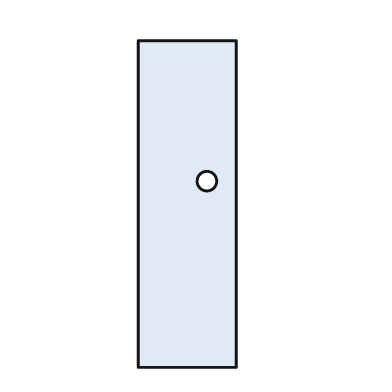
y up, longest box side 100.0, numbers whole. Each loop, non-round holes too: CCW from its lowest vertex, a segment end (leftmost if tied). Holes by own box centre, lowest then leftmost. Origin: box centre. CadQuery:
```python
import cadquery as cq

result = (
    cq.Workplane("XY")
    .moveTo(-15.0, -50.0)
    .lineTo(15.0, -50.0)
    .lineTo(15.0, 50.0)
    .lineTo(-15.0, 50.0)
    .close()
    .moveTo(6.0, 7.0)
    .circle(3.0)
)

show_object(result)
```